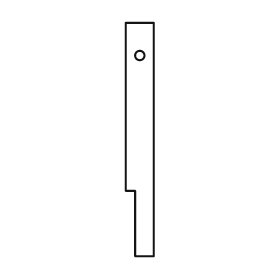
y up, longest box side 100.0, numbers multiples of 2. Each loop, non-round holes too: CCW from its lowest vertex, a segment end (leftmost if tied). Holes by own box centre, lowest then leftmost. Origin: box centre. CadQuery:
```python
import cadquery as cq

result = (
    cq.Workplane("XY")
    .moveTo(-2.0, -50.0)
    .lineTo(6.0, -50.0)
    .lineTo(6.0, 50.0)
    .lineTo(-6.0, 50.0)
    .lineTo(-6.0, -22.0)
    .lineTo(-2.0, -22.0)
    .close()
    .moveTo(0.0, 36.0)
    .circle(2.0)
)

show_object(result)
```